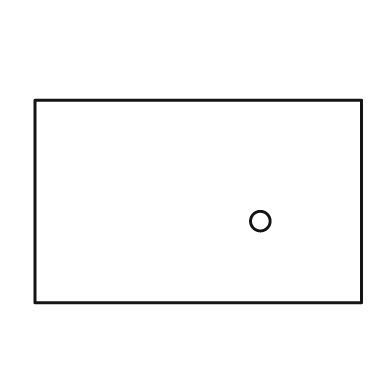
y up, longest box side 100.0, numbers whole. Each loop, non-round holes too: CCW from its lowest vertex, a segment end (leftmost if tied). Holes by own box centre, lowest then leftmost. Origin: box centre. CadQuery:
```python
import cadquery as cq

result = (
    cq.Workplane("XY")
    .moveTo(-50.0, -31.0)
    .lineTo(50.0, -31.0)
    .lineTo(50.0, 31.0)
    .lineTo(-50.0, 31.0)
    .close()
    .moveTo(19.0, -6.0)
    .circle(3.0)
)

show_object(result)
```